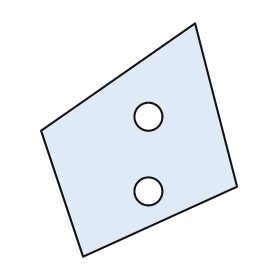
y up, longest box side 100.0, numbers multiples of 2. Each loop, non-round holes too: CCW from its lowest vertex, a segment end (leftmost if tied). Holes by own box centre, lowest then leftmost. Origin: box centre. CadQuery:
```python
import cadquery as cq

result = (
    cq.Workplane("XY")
    .moveTo(-24.0, -50.0)
    .lineTo(42.0, -20.0)
    .lineTo(24.0, 50.0)
    .lineTo(-42.0, 4.0)
    .close()
    .moveTo(4.0, -22.0)
    .circle(6.0)
    .moveTo(4.0, 10.0)
    .circle(6.0)
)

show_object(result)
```